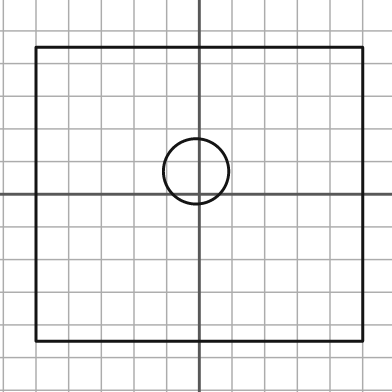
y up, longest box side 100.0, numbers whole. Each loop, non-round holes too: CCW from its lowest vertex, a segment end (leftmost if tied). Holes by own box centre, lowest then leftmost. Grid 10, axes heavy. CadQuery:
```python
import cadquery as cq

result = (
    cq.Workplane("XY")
    .moveTo(-50.0, -45.0)
    .lineTo(50.0, -45.0)
    .lineTo(50.0, 45.0)
    .lineTo(-50.0, 45.0)
    .close()
    .moveTo(-1.0, 7.0)
    .circle(10.0)
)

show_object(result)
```